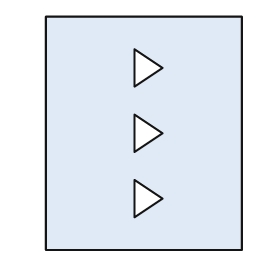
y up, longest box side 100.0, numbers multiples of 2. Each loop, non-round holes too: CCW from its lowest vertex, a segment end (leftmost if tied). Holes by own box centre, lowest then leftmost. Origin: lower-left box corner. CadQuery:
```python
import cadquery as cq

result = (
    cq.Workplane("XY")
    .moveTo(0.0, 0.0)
    .lineTo(84.0, 0.0)
    .lineTo(84.0, 100.0)
    .lineTo(0.0, 100.0)
    .close()
    .moveTo(38.0, 14.0)
    .lineTo(50.0, 22.0)
    .lineTo(38.0, 30.0)
    .close()
    .moveTo(38.0, 42.0)
    .lineTo(50.0, 50.0)
    .lineTo(38.0, 58.0)
    .close()
    .moveTo(38.0, 70.0)
    .lineTo(50.0, 78.0)
    .lineTo(38.0, 86.0)
    .close()
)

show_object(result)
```